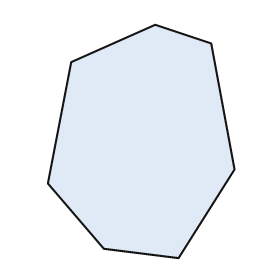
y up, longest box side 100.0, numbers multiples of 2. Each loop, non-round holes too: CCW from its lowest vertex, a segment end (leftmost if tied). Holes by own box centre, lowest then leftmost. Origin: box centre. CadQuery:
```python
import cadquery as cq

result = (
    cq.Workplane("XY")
    .moveTo(16.0, -50.0)
    .lineTo(40.0, -12.0)
    .lineTo(30.0, 42.0)
    .lineTo(6.0, 50.0)
    .lineTo(-30.0, 34.0)
    .lineTo(-40.0, -18.0)
    .lineTo(-16.0, -46.0)
    .close()
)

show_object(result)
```